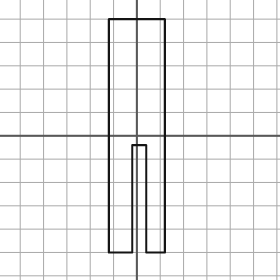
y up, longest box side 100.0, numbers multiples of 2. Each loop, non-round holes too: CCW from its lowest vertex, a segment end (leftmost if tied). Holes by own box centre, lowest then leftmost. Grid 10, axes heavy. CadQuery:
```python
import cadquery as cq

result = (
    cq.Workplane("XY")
    .moveTo(-12.0, -50.0)
    .lineTo(-2.0, -50.0)
    .lineTo(-2.0, -4.0)
    .lineTo(4.0, -4.0)
    .lineTo(4.0, -50.0)
    .lineTo(12.0, -50.0)
    .lineTo(12.0, 50.0)
    .lineTo(-12.0, 50.0)
    .close()
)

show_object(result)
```